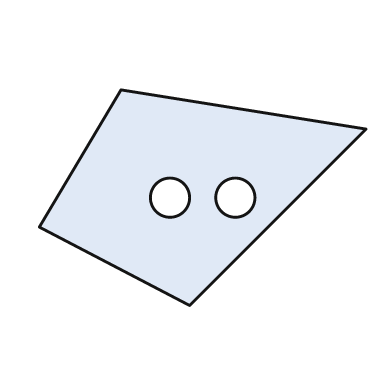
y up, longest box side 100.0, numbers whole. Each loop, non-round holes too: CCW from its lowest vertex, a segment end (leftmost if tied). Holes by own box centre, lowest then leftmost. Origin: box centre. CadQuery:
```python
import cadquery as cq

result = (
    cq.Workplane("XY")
    .moveTo(-4.0, -33.0)
    .lineTo(50.0, 21.0)
    .lineTo(-25.0, 33.0)
    .lineTo(-50.0, -9.0)
    .close()
    .moveTo(-10.0, 0.0)
    .circle(6.0)
    .moveTo(10.0, 0.0)
    .circle(6.0)
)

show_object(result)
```